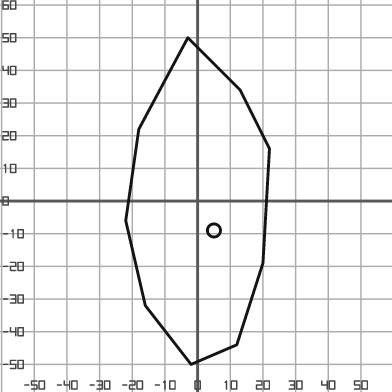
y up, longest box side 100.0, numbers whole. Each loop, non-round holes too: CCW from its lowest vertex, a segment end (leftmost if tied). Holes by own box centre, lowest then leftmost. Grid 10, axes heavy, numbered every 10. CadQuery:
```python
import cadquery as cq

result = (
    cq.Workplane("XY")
    .moveTo(-2.0, -50.0)
    .lineTo(12.0, -44.0)
    .lineTo(20.0, -19.0)
    .lineTo(22.0, 16.0)
    .lineTo(13.0, 34.0)
    .lineTo(-3.0, 50.0)
    .lineTo(-18.0, 22.0)
    .lineTo(-22.0, -6.0)
    .lineTo(-16.0, -32.0)
    .close()
    .moveTo(5.0, -9.0)
    .circle(2.0)
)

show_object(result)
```